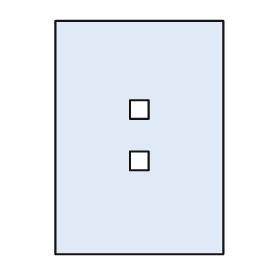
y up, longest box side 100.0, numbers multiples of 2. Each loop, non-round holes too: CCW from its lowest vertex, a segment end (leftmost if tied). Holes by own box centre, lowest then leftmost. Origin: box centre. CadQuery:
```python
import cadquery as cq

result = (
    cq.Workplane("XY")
    .moveTo(-36.0, -50.0)
    .lineTo(36.0, -50.0)
    .lineTo(36.0, 50.0)
    .lineTo(-36.0, 50.0)
    .close()
    .moveTo(-4.0, -14.0)
    .lineTo(4.0, -14.0)
    .lineTo(4.0, -6.0)
    .lineTo(-4.0, -6.0)
    .close()
    .moveTo(-4.0, 8.0)
    .lineTo(4.0, 8.0)
    .lineTo(4.0, 16.0)
    .lineTo(-4.0, 16.0)
    .close()
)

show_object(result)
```